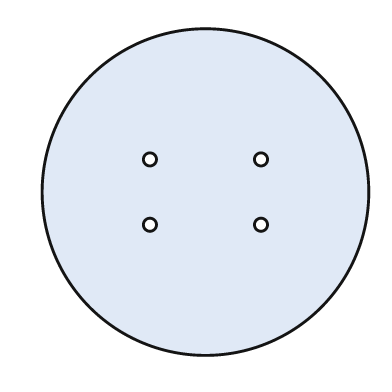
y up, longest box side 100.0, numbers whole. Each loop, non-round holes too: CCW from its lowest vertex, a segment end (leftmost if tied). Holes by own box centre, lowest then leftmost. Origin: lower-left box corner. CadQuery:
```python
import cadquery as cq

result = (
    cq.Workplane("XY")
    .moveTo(50.0, 50.0)
    .circle(50.0)
    .moveTo(33.0, 40.0)
    .circle(2.0)
    .moveTo(67.0, 40.0)
    .circle(2.0)
    .moveTo(33.0, 60.0)
    .circle(2.0)
    .moveTo(67.0, 60.0)
    .circle(2.0)
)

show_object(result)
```